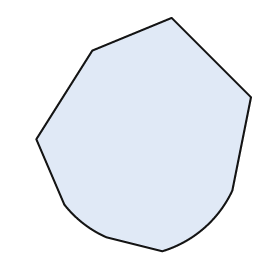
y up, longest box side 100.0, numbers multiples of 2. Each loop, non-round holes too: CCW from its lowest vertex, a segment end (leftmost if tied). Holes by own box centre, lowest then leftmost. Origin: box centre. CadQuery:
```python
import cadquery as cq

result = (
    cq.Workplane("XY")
    .moveTo(8.0, -50.0)
    .threePointArc((26.0, -40.0), (38.0, -24.0))
    .lineTo(46.0, 16.0)
    .lineTo(12.0, 50.0)
    .lineTo(-22.0, 36.0)
    .lineTo(-46.0, -2.0)
    .lineTo(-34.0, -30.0)
    .threePointArc((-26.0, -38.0), (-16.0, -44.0))
    .close()
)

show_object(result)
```